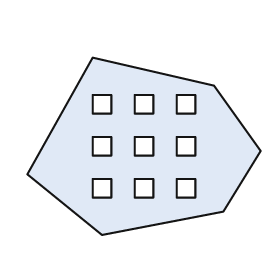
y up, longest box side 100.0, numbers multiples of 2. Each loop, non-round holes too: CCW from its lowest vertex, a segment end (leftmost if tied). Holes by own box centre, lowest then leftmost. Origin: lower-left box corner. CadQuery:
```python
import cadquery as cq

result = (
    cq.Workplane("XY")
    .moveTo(32.0, 0.0)
    .lineTo(84.0, 10.0)
    .lineTo(100.0, 36.0)
    .lineTo(80.0, 64.0)
    .lineTo(28.0, 76.0)
    .lineTo(0.0, 26.0)
    .close()
    .moveTo(28.0, 16.0)
    .lineTo(36.0, 16.0)
    .lineTo(36.0, 24.0)
    .lineTo(28.0, 24.0)
    .close()
    .moveTo(46.0, 16.0)
    .lineTo(54.0, 16.0)
    .lineTo(54.0, 24.0)
    .lineTo(46.0, 24.0)
    .close()
    .moveTo(64.0, 16.0)
    .lineTo(72.0, 16.0)
    .lineTo(72.0, 24.0)
    .lineTo(64.0, 24.0)
    .close()
    .moveTo(28.0, 34.0)
    .lineTo(36.0, 34.0)
    .lineTo(36.0, 42.0)
    .lineTo(28.0, 42.0)
    .close()
    .moveTo(46.0, 34.0)
    .lineTo(54.0, 34.0)
    .lineTo(54.0, 42.0)
    .lineTo(46.0, 42.0)
    .close()
    .moveTo(64.0, 34.0)
    .lineTo(72.0, 34.0)
    .lineTo(72.0, 42.0)
    .lineTo(64.0, 42.0)
    .close()
    .moveTo(28.0, 52.0)
    .lineTo(36.0, 52.0)
    .lineTo(36.0, 60.0)
    .lineTo(28.0, 60.0)
    .close()
    .moveTo(46.0, 52.0)
    .lineTo(54.0, 52.0)
    .lineTo(54.0, 60.0)
    .lineTo(46.0, 60.0)
    .close()
    .moveTo(64.0, 52.0)
    .lineTo(72.0, 52.0)
    .lineTo(72.0, 60.0)
    .lineTo(64.0, 60.0)
    .close()
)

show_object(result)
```